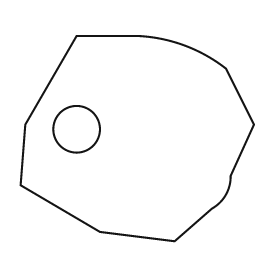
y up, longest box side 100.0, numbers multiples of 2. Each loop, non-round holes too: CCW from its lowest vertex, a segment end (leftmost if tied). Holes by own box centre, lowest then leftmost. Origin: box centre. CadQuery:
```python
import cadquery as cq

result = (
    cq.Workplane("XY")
    .moveTo(16.0, -44.0)
    .lineTo(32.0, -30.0)
    .threePointArc((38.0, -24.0), (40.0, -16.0))
    .lineTo(50.0, 6.0)
    .lineTo(38.0, 30.0)
    .threePointArc((20.0, 40.0), (0.0, 44.0))
    .lineTo(-26.0, 44.0)
    .lineTo(-48.0, 6.0)
    .lineTo(-50.0, -20.0)
    .lineTo(-16.0, -40.0)
    .close()
    .moveTo(-26.0, 4.0)
    .circle(10.0)
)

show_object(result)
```